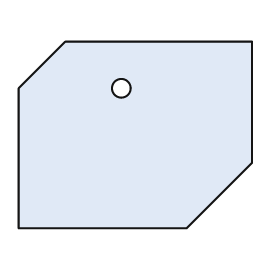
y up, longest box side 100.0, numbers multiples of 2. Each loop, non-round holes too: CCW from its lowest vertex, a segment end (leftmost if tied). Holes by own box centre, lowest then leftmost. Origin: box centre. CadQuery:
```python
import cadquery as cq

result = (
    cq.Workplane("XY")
    .moveTo(-50.0, -40.0)
    .lineTo(22.0, -40.0)
    .lineTo(50.0, -12.0)
    .lineTo(50.0, 40.0)
    .lineTo(-30.0, 40.0)
    .lineTo(-50.0, 20.0)
    .close()
    .moveTo(-6.0, 20.0)
    .circle(4.0)
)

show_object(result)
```